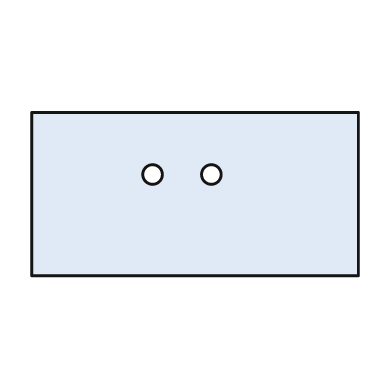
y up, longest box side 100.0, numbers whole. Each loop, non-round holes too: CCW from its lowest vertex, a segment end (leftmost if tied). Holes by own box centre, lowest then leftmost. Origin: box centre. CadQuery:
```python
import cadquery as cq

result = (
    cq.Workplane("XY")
    .moveTo(-50.0, -25.0)
    .lineTo(50.0, -25.0)
    .lineTo(50.0, 25.0)
    .lineTo(-50.0, 25.0)
    .close()
    .moveTo(-13.0, 6.0)
    .circle(3.0)
    .moveTo(5.0, 6.0)
    .circle(3.0)
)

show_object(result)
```